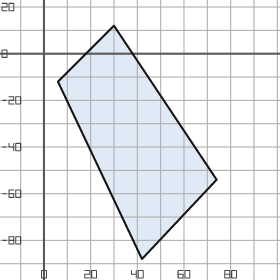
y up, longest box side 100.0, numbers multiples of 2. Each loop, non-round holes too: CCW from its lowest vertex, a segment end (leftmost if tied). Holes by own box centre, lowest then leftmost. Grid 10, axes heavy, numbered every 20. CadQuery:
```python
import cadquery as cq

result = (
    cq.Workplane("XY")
    .moveTo(42.0, -88.0)
    .lineTo(74.0, -54.0)
    .lineTo(30.0, 12.0)
    .lineTo(6.0, -12.0)
    .close()
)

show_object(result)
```